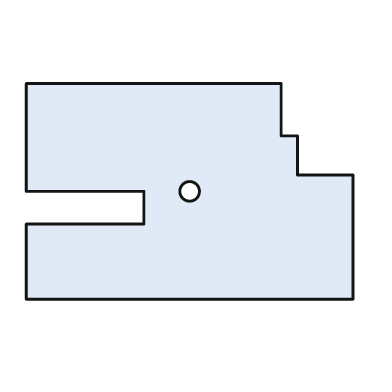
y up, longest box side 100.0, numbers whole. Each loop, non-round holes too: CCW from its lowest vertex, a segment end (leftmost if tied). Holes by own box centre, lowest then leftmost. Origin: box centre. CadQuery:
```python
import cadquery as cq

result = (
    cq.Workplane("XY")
    .moveTo(-50.0, -33.0)
    .lineTo(50.0, -33.0)
    .lineTo(50.0, 5.0)
    .lineTo(33.0, 5.0)
    .lineTo(33.0, 17.0)
    .lineTo(28.0, 17.0)
    .lineTo(28.0, 33.0)
    .lineTo(-50.0, 33.0)
    .lineTo(-50.0, 0.0)
    .lineTo(-14.0, 0.0)
    .lineTo(-14.0, -10.0)
    .lineTo(-50.0, -10.0)
    .close()
    .moveTo(0.0, 0.0)
    .circle(3.0)
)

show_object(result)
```